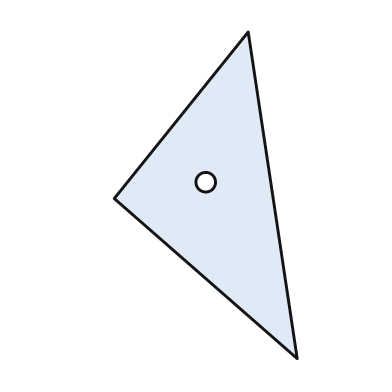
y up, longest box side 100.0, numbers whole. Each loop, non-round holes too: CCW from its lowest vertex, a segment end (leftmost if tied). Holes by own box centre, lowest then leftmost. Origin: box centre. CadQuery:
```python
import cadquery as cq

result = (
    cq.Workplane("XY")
    .moveTo(28.0, -50.0)
    .lineTo(13.0, 50.0)
    .lineTo(-28.0, -1.0)
    .close()
    .moveTo(0.0, 4.0)
    .circle(3.0)
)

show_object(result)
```